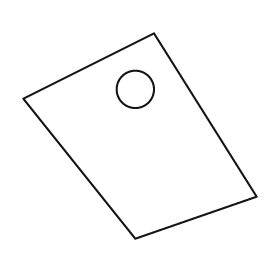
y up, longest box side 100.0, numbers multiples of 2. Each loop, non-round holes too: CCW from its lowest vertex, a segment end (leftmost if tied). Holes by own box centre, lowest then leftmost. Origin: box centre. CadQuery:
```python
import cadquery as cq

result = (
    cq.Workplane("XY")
    .moveTo(-2.0, -44.0)
    .lineTo(50.0, -26.0)
    .lineTo(6.0, 44.0)
    .lineTo(-50.0, 16.0)
    .close()
    .moveTo(-2.0, 20.0)
    .circle(8.0)
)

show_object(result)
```